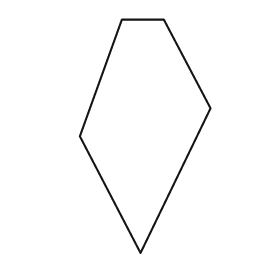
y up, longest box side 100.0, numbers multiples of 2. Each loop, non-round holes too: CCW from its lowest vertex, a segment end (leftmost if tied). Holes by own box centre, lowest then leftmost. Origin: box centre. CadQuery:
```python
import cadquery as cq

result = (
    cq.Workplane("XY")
    .moveTo(-2.0, -50.0)
    .lineTo(28.0, 12.0)
    .lineTo(8.0, 50.0)
    .lineTo(-10.0, 50.0)
    .lineTo(-28.0, 0.0)
    .close()
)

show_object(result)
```